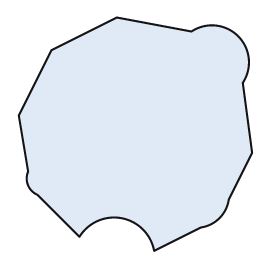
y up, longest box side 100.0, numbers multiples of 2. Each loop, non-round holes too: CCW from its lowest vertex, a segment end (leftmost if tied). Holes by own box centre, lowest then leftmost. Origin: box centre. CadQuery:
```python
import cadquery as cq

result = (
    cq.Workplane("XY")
    .moveTo(8.0, -50.0)
    .lineTo(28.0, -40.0)
    .threePointArc((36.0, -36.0), (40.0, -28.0))
    .lineTo(50.0, -8.0)
    .lineTo(46.0, 22.0)
    .threePointArc((44.0, 42.0), (24.0, 44.0))
    .lineTo(-8.0, 50.0)
    .lineTo(-36.0, 36.0)
    .lineTo(-50.0, 8.0)
    .lineTo(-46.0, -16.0)
    .threePointArc((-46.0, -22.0), (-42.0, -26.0))
    .lineTo(-24.0, -44.0)
    .threePointArc((-6.0, -36.0), (8.0, -50.0))
    .close()
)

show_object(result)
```